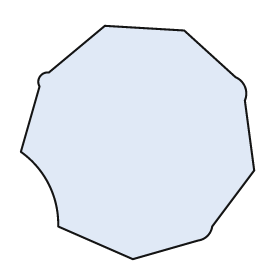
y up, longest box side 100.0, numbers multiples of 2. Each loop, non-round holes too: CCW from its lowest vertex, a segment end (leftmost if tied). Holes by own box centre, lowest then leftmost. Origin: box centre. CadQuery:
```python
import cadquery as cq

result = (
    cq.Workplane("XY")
    .moveTo(-2.0, -50.0)
    .lineTo(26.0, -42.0)
    .threePointArc((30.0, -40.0), (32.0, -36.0))
    .lineTo(50.0, -12.0)
    .lineTo(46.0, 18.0)
    .threePointArc((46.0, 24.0), (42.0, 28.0))
    .lineTo(20.0, 48.0)
    .lineTo(-14.0, 50.0)
    .lineTo(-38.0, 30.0)
    .threePointArc((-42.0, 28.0), (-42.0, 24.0))
    .lineTo(-50.0, -4.0)
    .threePointArc((-38.0, -18.0), (-34.0, -36.0))
    .close()
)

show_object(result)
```